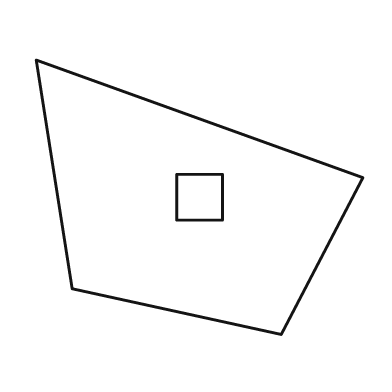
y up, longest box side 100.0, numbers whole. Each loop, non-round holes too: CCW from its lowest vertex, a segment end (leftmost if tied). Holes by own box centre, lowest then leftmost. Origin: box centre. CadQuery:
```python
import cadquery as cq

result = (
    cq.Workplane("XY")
    .moveTo(25.0, -42.0)
    .lineTo(50.0, 6.0)
    .lineTo(-50.0, 42.0)
    .lineTo(-39.0, -28.0)
    .close()
    .moveTo(-7.0, -7.0)
    .lineTo(7.0, -7.0)
    .lineTo(7.0, 7.0)
    .lineTo(-7.0, 7.0)
    .close()
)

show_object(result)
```